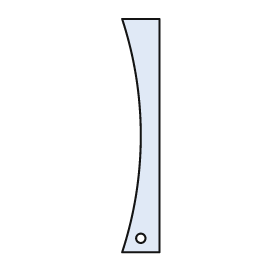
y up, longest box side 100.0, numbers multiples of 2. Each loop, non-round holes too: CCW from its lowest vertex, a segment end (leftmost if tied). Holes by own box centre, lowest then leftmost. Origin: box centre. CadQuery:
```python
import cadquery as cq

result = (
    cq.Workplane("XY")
    .moveTo(-8.0, -50.0)
    .lineTo(8.0, -50.0)
    .lineTo(8.0, 50.0)
    .lineTo(-8.0, 50.0)
    .threePointArc((0.0, 0.0), (-8.0, -50.0))
    .close()
    .moveTo(0.0, -44.0)
    .circle(2.0)
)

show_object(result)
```